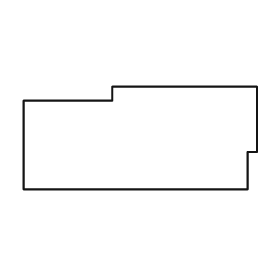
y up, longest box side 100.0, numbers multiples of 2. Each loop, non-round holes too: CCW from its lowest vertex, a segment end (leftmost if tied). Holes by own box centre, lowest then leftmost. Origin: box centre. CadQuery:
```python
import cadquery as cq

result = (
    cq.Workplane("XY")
    .moveTo(-50.0, -22.0)
    .lineTo(46.0, -22.0)
    .lineTo(46.0, -6.0)
    .lineTo(50.0, -6.0)
    .lineTo(50.0, 22.0)
    .lineTo(-12.0, 22.0)
    .lineTo(-12.0, 16.0)
    .lineTo(-50.0, 16.0)
    .close()
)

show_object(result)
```